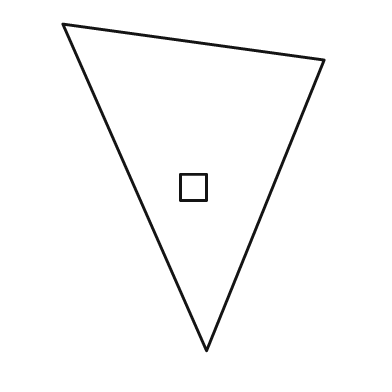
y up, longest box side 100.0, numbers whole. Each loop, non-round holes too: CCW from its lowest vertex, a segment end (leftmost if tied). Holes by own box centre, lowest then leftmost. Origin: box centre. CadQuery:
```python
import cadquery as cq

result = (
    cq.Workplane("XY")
    .moveTo(4.0, -50.0)
    .lineTo(40.0, 39.0)
    .lineTo(-40.0, 50.0)
    .close()
    .moveTo(-4.0, -4.0)
    .lineTo(4.0, -4.0)
    .lineTo(4.0, 4.0)
    .lineTo(-4.0, 4.0)
    .close()
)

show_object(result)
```